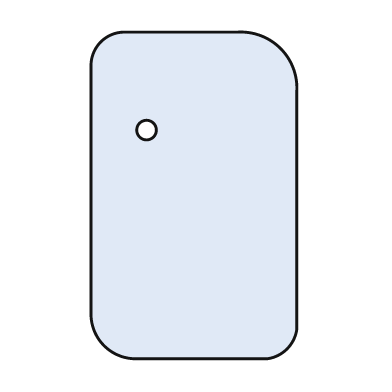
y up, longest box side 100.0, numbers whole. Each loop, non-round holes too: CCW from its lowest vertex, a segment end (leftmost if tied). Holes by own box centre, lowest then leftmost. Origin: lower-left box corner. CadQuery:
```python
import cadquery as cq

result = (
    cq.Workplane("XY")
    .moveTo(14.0, 0.0)
    .lineTo(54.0, 0.0)
    .threePointArc((60.0, 3.0), (63.0, 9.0))
    .lineTo(63.0, 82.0)
    .threePointArc((58.0, 95.0), (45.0, 100.0))
    .lineTo(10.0, 100.0)
    .threePointArc((3.0, 97.0), (0.0, 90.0))
    .lineTo(0.0, 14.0)
    .threePointArc((4.0, 4.0), (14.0, 0.0))
    .close()
    .moveTo(17.0, 70.0)
    .circle(3.0)
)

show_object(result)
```